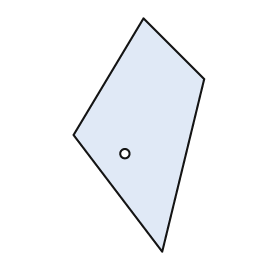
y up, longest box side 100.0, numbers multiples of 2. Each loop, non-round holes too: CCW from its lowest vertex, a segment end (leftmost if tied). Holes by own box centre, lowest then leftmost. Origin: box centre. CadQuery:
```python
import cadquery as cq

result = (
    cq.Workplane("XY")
    .moveTo(10.0, -50.0)
    .lineTo(28.0, 24.0)
    .lineTo(2.0, 50.0)
    .lineTo(-28.0, 0.0)
    .close()
    .moveTo(-6.0, -8.0)
    .circle(2.0)
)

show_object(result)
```